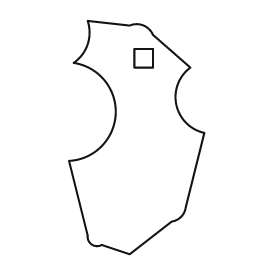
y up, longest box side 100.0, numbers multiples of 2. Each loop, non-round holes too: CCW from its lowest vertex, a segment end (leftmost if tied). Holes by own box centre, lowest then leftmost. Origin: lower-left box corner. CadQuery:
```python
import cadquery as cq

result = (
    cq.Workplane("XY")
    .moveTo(26.0, 0.0)
    .lineTo(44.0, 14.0)
    .threePointArc((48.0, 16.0), (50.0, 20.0))
    .lineTo(58.0, 52.0)
    .threePointArc((46.0, 64.0), (52.0, 80.0))
    .lineTo(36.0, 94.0)
    .threePointArc((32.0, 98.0), (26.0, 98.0))
    .lineTo(8.0, 100.0)
    .threePointArc((8.0, 90.0), (2.0, 82.0))
    .threePointArc((20.0, 60.0), (0.0, 40.0))
    .lineTo(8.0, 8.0)
    .threePointArc((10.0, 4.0), (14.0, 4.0))
    .close()
    .moveTo(28.0, 80.0)
    .lineTo(36.0, 80.0)
    .lineTo(36.0, 88.0)
    .lineTo(28.0, 88.0)
    .close()
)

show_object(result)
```